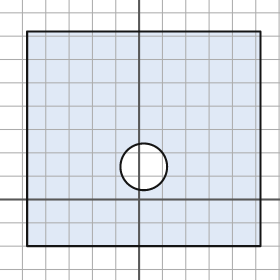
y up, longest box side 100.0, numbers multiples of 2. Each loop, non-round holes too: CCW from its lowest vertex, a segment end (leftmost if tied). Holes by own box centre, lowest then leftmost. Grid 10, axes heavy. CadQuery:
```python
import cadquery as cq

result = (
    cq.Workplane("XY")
    .moveTo(-48.0, -20.0)
    .lineTo(52.0, -20.0)
    .lineTo(52.0, 72.0)
    .lineTo(-48.0, 72.0)
    .close()
    .moveTo(2.0, 14.0)
    .circle(10.0)
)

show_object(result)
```